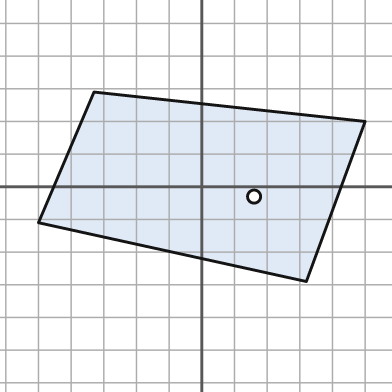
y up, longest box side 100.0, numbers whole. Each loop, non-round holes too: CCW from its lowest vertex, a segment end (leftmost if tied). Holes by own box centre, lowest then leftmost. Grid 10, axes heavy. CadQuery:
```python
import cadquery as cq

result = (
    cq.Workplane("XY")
    .moveTo(32.0, -29.0)
    .lineTo(50.0, 20.0)
    .lineTo(-33.0, 29.0)
    .lineTo(-50.0, -11.0)
    .close()
    .moveTo(16.0, -3.0)
    .circle(2.0)
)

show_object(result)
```